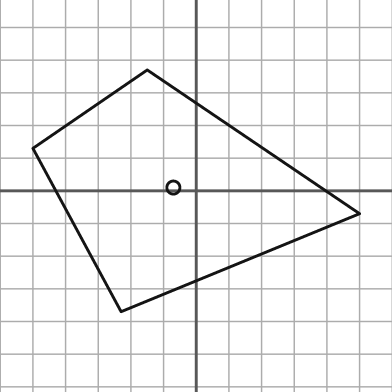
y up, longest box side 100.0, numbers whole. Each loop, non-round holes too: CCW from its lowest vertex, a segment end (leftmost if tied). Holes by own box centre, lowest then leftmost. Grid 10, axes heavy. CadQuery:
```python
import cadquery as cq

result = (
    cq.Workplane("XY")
    .moveTo(-23.0, -37.0)
    .lineTo(50.0, -7.0)
    .lineTo(-15.0, 37.0)
    .lineTo(-50.0, 13.0)
    .close()
    .moveTo(-7.0, 1.0)
    .circle(2.0)
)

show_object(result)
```